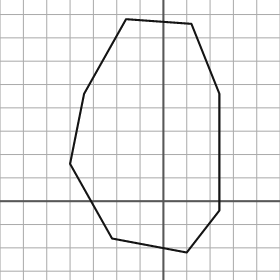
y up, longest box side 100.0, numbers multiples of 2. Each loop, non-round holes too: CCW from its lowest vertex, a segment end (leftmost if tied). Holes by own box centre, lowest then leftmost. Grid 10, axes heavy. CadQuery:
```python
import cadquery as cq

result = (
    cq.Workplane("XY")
    .moveTo(10.0, -22.0)
    .lineTo(24.0, -4.0)
    .lineTo(24.0, 46.0)
    .lineTo(12.0, 76.0)
    .lineTo(-16.0, 78.0)
    .lineTo(-34.0, 46.0)
    .lineTo(-40.0, 16.0)
    .lineTo(-22.0, -16.0)
    .close()
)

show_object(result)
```